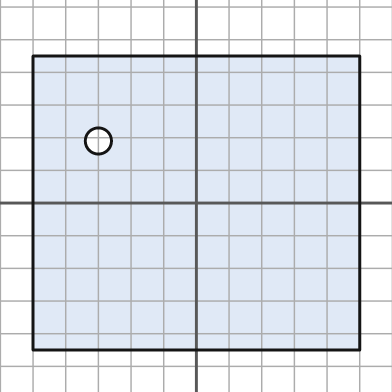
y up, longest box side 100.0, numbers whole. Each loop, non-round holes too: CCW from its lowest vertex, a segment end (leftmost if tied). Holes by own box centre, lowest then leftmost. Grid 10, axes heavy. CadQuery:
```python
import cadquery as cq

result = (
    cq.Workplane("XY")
    .moveTo(-50.0, -45.0)
    .lineTo(50.0, -45.0)
    .lineTo(50.0, 45.0)
    .lineTo(-50.0, 45.0)
    .close()
    .moveTo(-30.0, 19.0)
    .circle(4.0)
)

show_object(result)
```